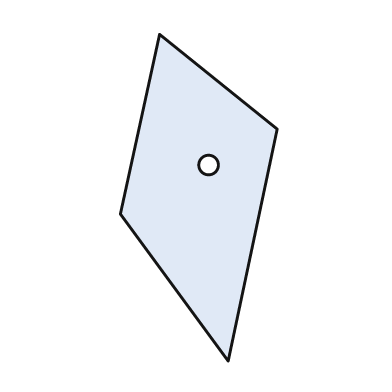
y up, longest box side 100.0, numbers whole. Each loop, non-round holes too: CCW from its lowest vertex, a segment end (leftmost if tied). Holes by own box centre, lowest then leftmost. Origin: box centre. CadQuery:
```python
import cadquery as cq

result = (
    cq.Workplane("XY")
    .moveTo(9.0, -50.0)
    .lineTo(24.0, 21.0)
    .lineTo(-12.0, 50.0)
    .lineTo(-24.0, -5.0)
    .close()
    .moveTo(3.0, 10.0)
    .circle(3.0)
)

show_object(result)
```